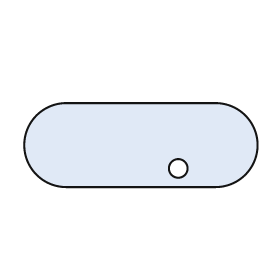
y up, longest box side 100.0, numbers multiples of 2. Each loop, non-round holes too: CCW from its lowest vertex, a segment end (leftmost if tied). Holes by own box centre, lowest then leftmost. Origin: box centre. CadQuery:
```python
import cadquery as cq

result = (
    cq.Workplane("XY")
    .moveTo(-32.0, -18.0)
    .lineTo(32.0, -18.0)
    .threePointArc((50.0, 0.0), (32.0, 18.0))
    .lineTo(-32.0, 18.0)
    .threePointArc((-50.0, 0.0), (-32.0, -18.0))
    .close()
    .moveTo(16.0, -10.0)
    .circle(4.0)
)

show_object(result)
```